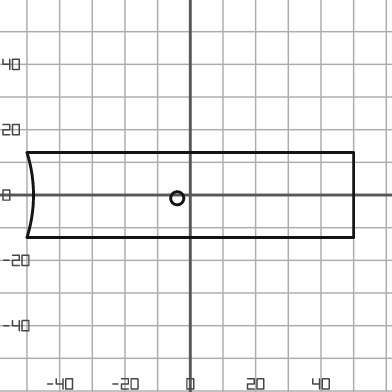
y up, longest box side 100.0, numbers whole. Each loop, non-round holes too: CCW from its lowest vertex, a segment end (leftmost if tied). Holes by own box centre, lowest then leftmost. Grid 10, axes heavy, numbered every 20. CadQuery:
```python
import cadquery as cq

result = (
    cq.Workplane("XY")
    .moveTo(-50.0, -13.0)
    .lineTo(50.0, -13.0)
    .lineTo(50.0, 13.0)
    .lineTo(-50.0, 13.0)
    .threePointArc((-48.0, 0.0), (-50.0, -13.0))
    .close()
    .moveTo(-4.0, -1.0)
    .circle(2.0)
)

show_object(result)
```